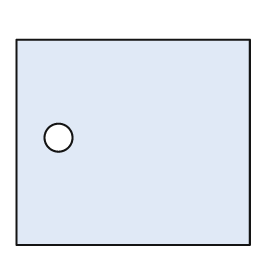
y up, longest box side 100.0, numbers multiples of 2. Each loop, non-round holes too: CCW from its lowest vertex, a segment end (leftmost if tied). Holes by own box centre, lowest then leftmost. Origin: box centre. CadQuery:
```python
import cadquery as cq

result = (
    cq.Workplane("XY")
    .moveTo(-50.0, -44.0)
    .lineTo(50.0, -44.0)
    .lineTo(50.0, 44.0)
    .lineTo(-50.0, 44.0)
    .close()
    .moveTo(-32.0, 2.0)
    .circle(6.0)
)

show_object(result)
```